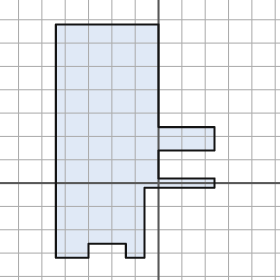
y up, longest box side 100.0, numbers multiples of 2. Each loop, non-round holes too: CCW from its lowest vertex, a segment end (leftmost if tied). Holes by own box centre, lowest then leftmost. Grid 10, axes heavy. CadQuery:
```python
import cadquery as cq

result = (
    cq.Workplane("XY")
    .moveTo(-44.0, -32.0)
    .lineTo(-30.0, -32.0)
    .lineTo(-30.0, -26.0)
    .lineTo(-14.0, -26.0)
    .lineTo(-14.0, -32.0)
    .lineTo(-6.0, -32.0)
    .lineTo(-6.0, -2.0)
    .lineTo(24.0, -2.0)
    .lineTo(24.0, 2.0)
    .lineTo(0.0, 2.0)
    .lineTo(0.0, 14.0)
    .lineTo(24.0, 14.0)
    .lineTo(24.0, 24.0)
    .lineTo(0.0, 24.0)
    .lineTo(0.0, 68.0)
    .lineTo(-44.0, 68.0)
    .close()
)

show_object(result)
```